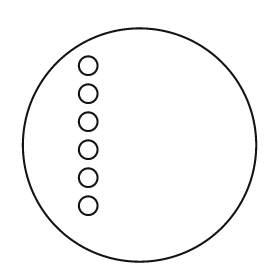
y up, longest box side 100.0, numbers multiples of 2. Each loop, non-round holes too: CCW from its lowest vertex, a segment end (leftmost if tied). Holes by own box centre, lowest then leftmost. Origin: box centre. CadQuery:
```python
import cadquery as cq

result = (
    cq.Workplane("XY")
    .moveTo(0.0, 0.0)
    .circle(50.0)
    .moveTo(-22.0, -26.0)
    .circle(4.0)
    .moveTo(-22.0, -14.0)
    .circle(4.0)
    .moveTo(-22.0, -2.0)
    .circle(4.0)
    .moveTo(-22.0, 10.0)
    .circle(4.0)
    .moveTo(-22.0, 22.0)
    .circle(4.0)
    .moveTo(-22.0, 34.0)
    .circle(4.0)
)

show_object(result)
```